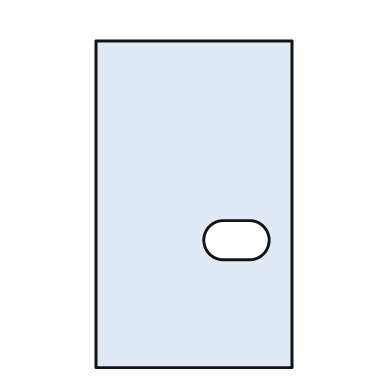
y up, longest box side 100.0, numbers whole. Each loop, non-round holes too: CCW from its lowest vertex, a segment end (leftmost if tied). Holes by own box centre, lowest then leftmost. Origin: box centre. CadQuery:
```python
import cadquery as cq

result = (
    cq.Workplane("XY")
    .moveTo(-30.0, -50.0)
    .lineTo(30.0, -50.0)
    .lineTo(30.0, 50.0)
    .lineTo(-30.0, 50.0)
    .close()
    .moveTo(9.0, -17.0)
    .lineTo(17.0, -17.0)
    .threePointArc((23.0, -11.0), (17.0, -5.0))
    .lineTo(9.0, -5.0)
    .threePointArc((3.0, -11.0), (9.0, -17.0))
    .close()
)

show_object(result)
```